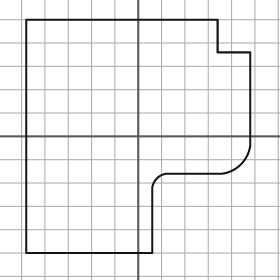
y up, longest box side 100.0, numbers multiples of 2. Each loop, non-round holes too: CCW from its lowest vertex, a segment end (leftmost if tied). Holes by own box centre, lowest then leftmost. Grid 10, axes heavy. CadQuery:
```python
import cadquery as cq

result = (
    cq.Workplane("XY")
    .moveTo(-48.0, -50.0)
    .lineTo(6.0, -50.0)
    .lineTo(6.0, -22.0)
    .threePointArc((8.0, -18.0), (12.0, -16.0))
    .lineTo(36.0, -16.0)
    .threePointArc((44.0, -12.0), (48.0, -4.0))
    .lineTo(48.0, 36.0)
    .lineTo(34.0, 36.0)
    .lineTo(34.0, 50.0)
    .lineTo(-48.0, 50.0)
    .close()
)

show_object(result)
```